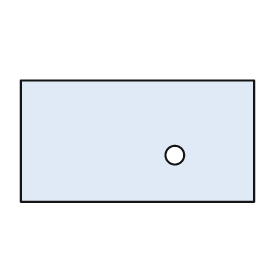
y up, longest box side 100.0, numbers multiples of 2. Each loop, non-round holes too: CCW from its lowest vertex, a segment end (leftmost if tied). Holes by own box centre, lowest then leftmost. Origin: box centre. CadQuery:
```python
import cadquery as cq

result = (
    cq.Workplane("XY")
    .moveTo(-50.0, -26.0)
    .lineTo(50.0, -26.0)
    .lineTo(50.0, 26.0)
    .lineTo(-50.0, 26.0)
    .close()
    .moveTo(16.0, -6.0)
    .circle(4.0)
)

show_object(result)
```